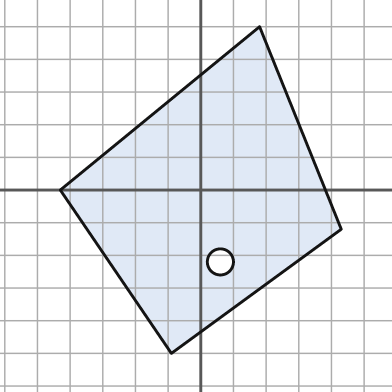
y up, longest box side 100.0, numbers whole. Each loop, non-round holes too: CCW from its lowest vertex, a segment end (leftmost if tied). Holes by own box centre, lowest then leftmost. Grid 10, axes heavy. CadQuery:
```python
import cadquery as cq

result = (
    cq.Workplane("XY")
    .moveTo(-9.0, -50.0)
    .lineTo(43.0, -12.0)
    .lineTo(18.0, 50.0)
    .lineTo(-43.0, 0.0)
    .close()
    .moveTo(6.0, -22.0)
    .circle(4.0)
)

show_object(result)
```